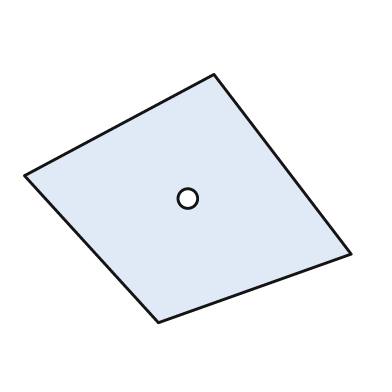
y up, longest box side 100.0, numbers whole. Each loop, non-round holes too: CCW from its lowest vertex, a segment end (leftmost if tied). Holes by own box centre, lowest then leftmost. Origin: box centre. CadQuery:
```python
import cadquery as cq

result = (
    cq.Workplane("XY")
    .moveTo(-9.0, -38.0)
    .lineTo(50.0, -17.0)
    .lineTo(8.0, 38.0)
    .lineTo(-50.0, 7.0)
    .close()
    .moveTo(0.0, 0.0)
    .circle(3.0)
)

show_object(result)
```